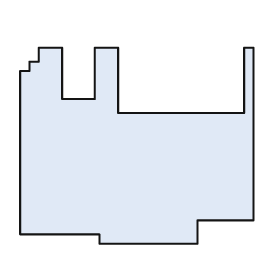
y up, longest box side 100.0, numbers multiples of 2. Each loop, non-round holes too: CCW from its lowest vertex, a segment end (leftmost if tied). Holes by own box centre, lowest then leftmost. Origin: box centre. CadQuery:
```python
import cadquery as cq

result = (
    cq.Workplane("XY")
    .moveTo(-16.0, -42.0)
    .lineTo(26.0, -42.0)
    .lineTo(26.0, -32.0)
    .lineTo(50.0, -32.0)
    .lineTo(50.0, 42.0)
    .lineTo(46.0, 42.0)
    .lineTo(46.0, 14.0)
    .lineTo(-8.0, 14.0)
    .lineTo(-8.0, 42.0)
    .lineTo(-18.0, 42.0)
    .lineTo(-18.0, 20.0)
    .lineTo(-32.0, 20.0)
    .lineTo(-32.0, 42.0)
    .lineTo(-42.0, 42.0)
    .lineTo(-42.0, 36.0)
    .lineTo(-46.0, 36.0)
    .lineTo(-46.0, 32.0)
    .lineTo(-50.0, 32.0)
    .lineTo(-50.0, -38.0)
    .lineTo(-16.0, -38.0)
    .close()
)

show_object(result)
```